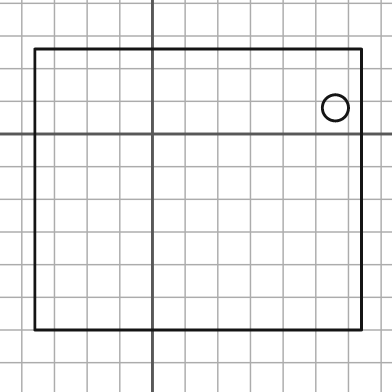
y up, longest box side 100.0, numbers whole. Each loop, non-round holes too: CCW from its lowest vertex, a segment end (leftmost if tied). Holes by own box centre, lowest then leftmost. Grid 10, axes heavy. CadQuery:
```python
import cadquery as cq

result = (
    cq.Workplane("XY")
    .moveTo(-36.0, -60.0)
    .lineTo(64.0, -60.0)
    .lineTo(64.0, 26.0)
    .lineTo(-36.0, 26.0)
    .close()
    .moveTo(56.0, 8.0)
    .circle(4.0)
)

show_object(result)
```